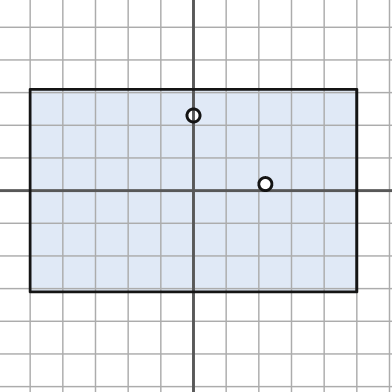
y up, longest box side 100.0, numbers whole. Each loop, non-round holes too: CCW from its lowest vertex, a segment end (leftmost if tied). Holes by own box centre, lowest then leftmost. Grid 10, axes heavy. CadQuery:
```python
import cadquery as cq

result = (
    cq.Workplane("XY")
    .moveTo(-50.0, -31.0)
    .lineTo(50.0, -31.0)
    .lineTo(50.0, 31.0)
    .lineTo(-50.0, 31.0)
    .close()
    .moveTo(22.0, 2.0)
    .circle(2.0)
    .moveTo(0.0, 23.0)
    .circle(2.0)
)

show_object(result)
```